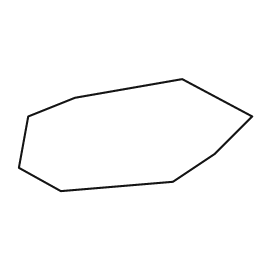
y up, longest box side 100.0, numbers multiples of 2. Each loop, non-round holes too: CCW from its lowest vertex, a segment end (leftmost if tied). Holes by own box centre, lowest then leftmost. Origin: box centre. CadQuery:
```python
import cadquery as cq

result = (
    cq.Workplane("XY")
    .moveTo(-32.0, -24.0)
    .lineTo(16.0, -20.0)
    .lineTo(34.0, -8.0)
    .lineTo(50.0, 8.0)
    .lineTo(20.0, 24.0)
    .lineTo(-26.0, 16.0)
    .lineTo(-46.0, 8.0)
    .lineTo(-50.0, -14.0)
    .close()
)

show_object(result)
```